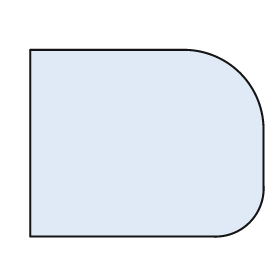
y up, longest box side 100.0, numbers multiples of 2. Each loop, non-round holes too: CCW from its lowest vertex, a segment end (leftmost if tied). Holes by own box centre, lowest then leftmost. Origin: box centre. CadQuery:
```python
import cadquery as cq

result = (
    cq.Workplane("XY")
    .moveTo(-50.0, -40.0)
    .lineTo(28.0, -40.0)
    .threePointArc((44.0, -34.0), (50.0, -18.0))
    .lineTo(50.0, 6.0)
    .threePointArc((40.0, 30.0), (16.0, 40.0))
    .lineTo(-50.0, 40.0)
    .close()
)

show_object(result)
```